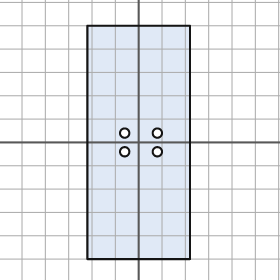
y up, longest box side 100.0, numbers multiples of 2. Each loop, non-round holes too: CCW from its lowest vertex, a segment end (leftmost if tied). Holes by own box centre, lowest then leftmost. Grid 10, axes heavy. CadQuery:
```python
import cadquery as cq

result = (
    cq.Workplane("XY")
    .moveTo(-22.0, -50.0)
    .lineTo(22.0, -50.0)
    .lineTo(22.0, 50.0)
    .lineTo(-22.0, 50.0)
    .close()
    .moveTo(-6.0, -4.0)
    .circle(2.0)
    .moveTo(8.0, -4.0)
    .circle(2.0)
    .moveTo(-6.0, 4.0)
    .circle(2.0)
    .moveTo(8.0, 4.0)
    .circle(2.0)
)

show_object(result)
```